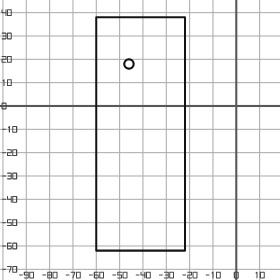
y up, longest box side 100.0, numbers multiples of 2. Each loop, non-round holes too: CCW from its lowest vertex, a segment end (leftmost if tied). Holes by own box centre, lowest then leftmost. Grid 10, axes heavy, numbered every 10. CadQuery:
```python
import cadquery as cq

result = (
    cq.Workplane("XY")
    .moveTo(-60.0, -62.0)
    .lineTo(-22.0, -62.0)
    .lineTo(-22.0, 38.0)
    .lineTo(-60.0, 38.0)
    .close()
    .moveTo(-46.0, 18.0)
    .circle(2.0)
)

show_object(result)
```